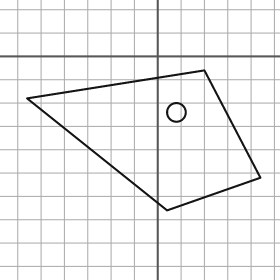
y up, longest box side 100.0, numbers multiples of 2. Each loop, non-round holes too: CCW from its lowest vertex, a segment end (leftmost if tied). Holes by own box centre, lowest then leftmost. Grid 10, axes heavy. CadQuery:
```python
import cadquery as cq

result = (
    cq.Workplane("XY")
    .moveTo(4.0, -66.0)
    .lineTo(44.0, -52.0)
    .lineTo(20.0, -6.0)
    .lineTo(-56.0, -18.0)
    .close()
    .moveTo(8.0, -24.0)
    .circle(4.0)
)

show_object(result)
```